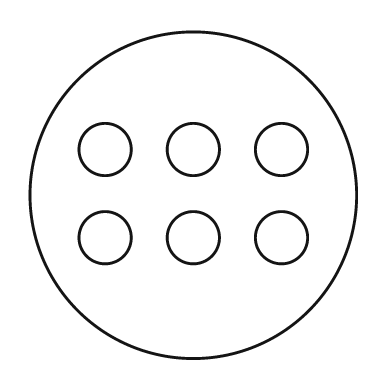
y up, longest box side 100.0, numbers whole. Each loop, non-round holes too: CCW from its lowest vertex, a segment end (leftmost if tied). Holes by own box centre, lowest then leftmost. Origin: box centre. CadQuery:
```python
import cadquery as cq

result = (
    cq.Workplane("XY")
    .moveTo(0.0, 0.0)
    .circle(50.0)
    .moveTo(-27.0, -13.0)
    .circle(8.0)
    .moveTo(0.0, -13.0)
    .circle(8.0)
    .moveTo(27.0, -13.0)
    .circle(8.0)
    .moveTo(-27.0, 14.0)
    .circle(8.0)
    .moveTo(0.0, 14.0)
    .circle(8.0)
    .moveTo(27.0, 14.0)
    .circle(8.0)
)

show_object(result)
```